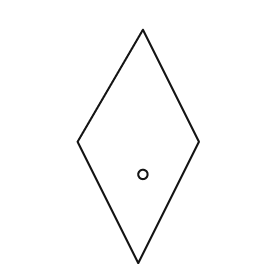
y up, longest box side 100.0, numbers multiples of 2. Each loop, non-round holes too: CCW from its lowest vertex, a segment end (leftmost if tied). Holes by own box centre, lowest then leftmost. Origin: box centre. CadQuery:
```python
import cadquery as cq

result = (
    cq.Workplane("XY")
    .moveTo(0.0, -50.0)
    .lineTo(26.0, 2.0)
    .lineTo(2.0, 50.0)
    .lineTo(-26.0, 2.0)
    .close()
    .moveTo(2.0, -12.0)
    .circle(2.0)
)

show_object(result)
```